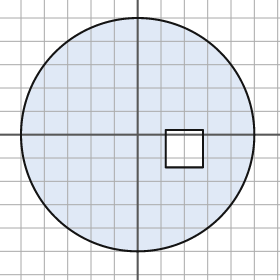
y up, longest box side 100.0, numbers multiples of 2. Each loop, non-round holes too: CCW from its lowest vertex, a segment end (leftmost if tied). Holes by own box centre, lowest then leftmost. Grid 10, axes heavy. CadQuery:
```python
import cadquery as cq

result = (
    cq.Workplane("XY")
    .moveTo(0.0, 0.0)
    .circle(50.0)
    .moveTo(12.0, -14.0)
    .lineTo(28.0, -14.0)
    .lineTo(28.0, 2.0)
    .lineTo(12.0, 2.0)
    .close()
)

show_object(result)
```